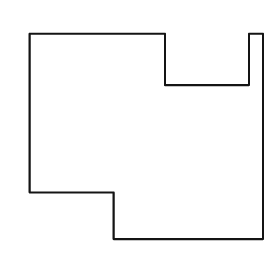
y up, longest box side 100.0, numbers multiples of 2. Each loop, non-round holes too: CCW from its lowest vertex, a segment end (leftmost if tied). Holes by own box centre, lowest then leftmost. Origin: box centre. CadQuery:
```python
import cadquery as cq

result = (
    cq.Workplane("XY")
    .moveTo(-14.0, -44.0)
    .lineTo(50.0, -44.0)
    .lineTo(50.0, 44.0)
    .lineTo(44.0, 44.0)
    .lineTo(44.0, 22.0)
    .lineTo(8.0, 22.0)
    .lineTo(8.0, 44.0)
    .lineTo(-50.0, 44.0)
    .lineTo(-50.0, -24.0)
    .lineTo(-14.0, -24.0)
    .close()
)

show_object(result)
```